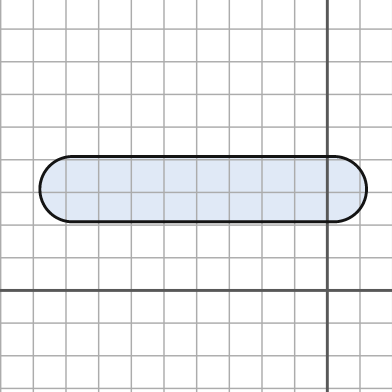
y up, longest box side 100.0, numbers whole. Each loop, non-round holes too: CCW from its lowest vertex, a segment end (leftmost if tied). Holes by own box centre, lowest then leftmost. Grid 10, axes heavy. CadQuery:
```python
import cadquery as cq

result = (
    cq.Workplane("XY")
    .moveTo(-78.0, 21.0)
    .lineTo(2.0, 21.0)
    .threePointArc((12.0, 31.0), (2.0, 41.0))
    .lineTo(-78.0, 41.0)
    .threePointArc((-88.0, 31.0), (-78.0, 21.0))
    .close()
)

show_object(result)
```